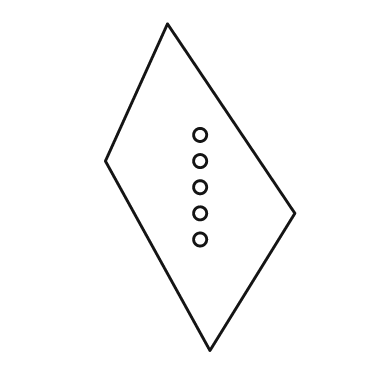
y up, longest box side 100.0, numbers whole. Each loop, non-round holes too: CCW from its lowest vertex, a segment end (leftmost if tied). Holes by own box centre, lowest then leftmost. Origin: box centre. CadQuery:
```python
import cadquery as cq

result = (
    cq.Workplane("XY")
    .moveTo(3.0, -50.0)
    .lineTo(29.0, -8.0)
    .lineTo(-10.0, 50.0)
    .lineTo(-29.0, 8.0)
    .close()
    .moveTo(0.0, -16.0)
    .circle(2.0)
    .moveTo(0.0, -8.0)
    .circle(2.0)
    .moveTo(0.0, 0.0)
    .circle(2.0)
    .moveTo(0.0, 8.0)
    .circle(2.0)
    .moveTo(0.0, 16.0)
    .circle(2.0)
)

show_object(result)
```